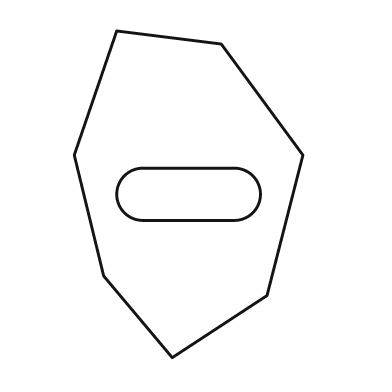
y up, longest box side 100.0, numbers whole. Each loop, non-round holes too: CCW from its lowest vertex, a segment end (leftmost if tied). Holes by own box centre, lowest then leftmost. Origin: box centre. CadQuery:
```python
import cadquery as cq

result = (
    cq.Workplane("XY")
    .moveTo(-5.0, -50.0)
    .lineTo(24.0, -31.0)
    .lineTo(35.0, 12.0)
    .lineTo(10.0, 46.0)
    .lineTo(-22.0, 50.0)
    .lineTo(-35.0, 12.0)
    .lineTo(-26.0, -25.0)
    .close()
    .moveTo(-14.0, -8.0)
    .lineTo(14.0, -8.0)
    .threePointArc((22.0, 0.0), (14.0, 8.0))
    .lineTo(-14.0, 8.0)
    .threePointArc((-22.0, 0.0), (-14.0, -8.0))
    .close()
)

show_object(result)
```